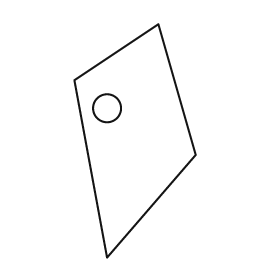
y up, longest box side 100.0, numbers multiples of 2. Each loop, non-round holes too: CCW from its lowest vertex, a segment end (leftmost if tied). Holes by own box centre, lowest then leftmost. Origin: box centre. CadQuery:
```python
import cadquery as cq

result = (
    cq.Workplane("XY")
    .moveTo(-12.0, -50.0)
    .lineTo(26.0, -6.0)
    .lineTo(10.0, 50.0)
    .lineTo(-26.0, 26.0)
    .close()
    .moveTo(-12.0, 14.0)
    .circle(6.0)
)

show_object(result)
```